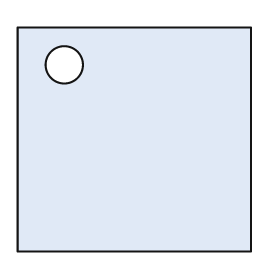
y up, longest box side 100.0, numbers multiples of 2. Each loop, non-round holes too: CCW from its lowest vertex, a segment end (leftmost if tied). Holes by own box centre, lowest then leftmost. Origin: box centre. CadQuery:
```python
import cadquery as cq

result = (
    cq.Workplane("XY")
    .moveTo(-50.0, -48.0)
    .lineTo(50.0, -48.0)
    .lineTo(50.0, 48.0)
    .lineTo(-50.0, 48.0)
    .close()
    .moveTo(-30.0, 32.0)
    .circle(8.0)
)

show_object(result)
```